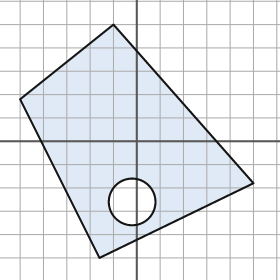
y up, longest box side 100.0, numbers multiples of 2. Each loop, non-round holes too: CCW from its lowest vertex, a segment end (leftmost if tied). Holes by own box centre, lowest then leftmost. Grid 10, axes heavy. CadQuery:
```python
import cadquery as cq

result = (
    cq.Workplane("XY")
    .moveTo(-16.0, -50.0)
    .lineTo(50.0, -18.0)
    .lineTo(-10.0, 50.0)
    .lineTo(-50.0, 18.0)
    .close()
    .moveTo(-2.0, -26.0)
    .circle(10.0)
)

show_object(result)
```